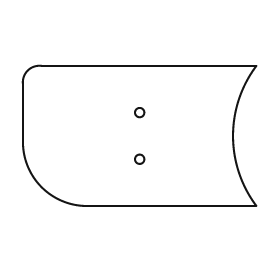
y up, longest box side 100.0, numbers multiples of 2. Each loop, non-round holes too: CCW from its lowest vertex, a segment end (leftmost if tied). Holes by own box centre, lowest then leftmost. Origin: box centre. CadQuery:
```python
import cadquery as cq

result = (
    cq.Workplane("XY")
    .moveTo(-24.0, -30.0)
    .lineTo(50.0, -30.0)
    .threePointArc((40.0, 0.0), (50.0, 30.0))
    .lineTo(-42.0, 30.0)
    .threePointArc((-48.0, 28.0), (-50.0, 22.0))
    .lineTo(-50.0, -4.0)
    .threePointArc((-42.0, -22.0), (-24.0, -30.0))
    .close()
    .moveTo(0.0, -10.0)
    .circle(2.0)
    .moveTo(0.0, 10.0)
    .circle(2.0)
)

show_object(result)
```